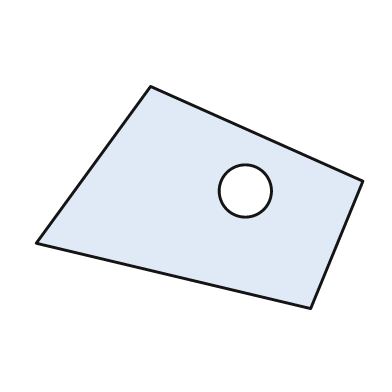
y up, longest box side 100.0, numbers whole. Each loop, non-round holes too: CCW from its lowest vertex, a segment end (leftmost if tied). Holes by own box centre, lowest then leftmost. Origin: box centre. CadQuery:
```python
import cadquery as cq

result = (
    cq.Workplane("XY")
    .moveTo(34.0, -34.0)
    .lineTo(50.0, 5.0)
    .lineTo(-15.0, 34.0)
    .lineTo(-50.0, -14.0)
    .close()
    .moveTo(14.0, 2.0)
    .circle(8.0)
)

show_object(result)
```